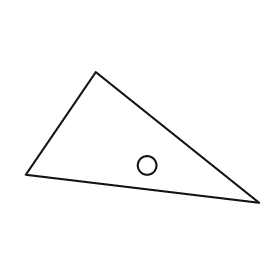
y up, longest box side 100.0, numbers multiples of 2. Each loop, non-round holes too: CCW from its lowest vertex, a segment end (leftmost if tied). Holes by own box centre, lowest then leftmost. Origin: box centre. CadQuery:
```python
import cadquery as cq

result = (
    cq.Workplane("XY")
    .moveTo(50.0, -28.0)
    .lineTo(-20.0, 28.0)
    .lineTo(-50.0, -16.0)
    .close()
    .moveTo(2.0, -12.0)
    .circle(4.0)
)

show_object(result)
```